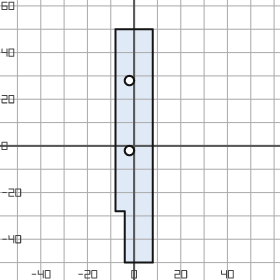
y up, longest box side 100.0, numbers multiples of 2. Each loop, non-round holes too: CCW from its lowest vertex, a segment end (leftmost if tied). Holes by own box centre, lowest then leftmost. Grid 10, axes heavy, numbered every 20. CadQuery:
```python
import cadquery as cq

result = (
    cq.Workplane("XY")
    .moveTo(-4.0, -50.0)
    .lineTo(8.0, -50.0)
    .lineTo(8.0, 50.0)
    .lineTo(-8.0, 50.0)
    .lineTo(-8.0, -28.0)
    .lineTo(-4.0, -28.0)
    .close()
    .moveTo(-2.0, -2.0)
    .circle(2.0)
    .moveTo(-2.0, 28.0)
    .circle(2.0)
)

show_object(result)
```